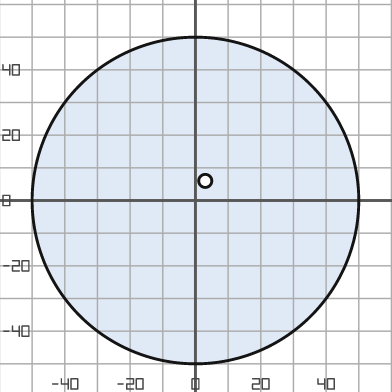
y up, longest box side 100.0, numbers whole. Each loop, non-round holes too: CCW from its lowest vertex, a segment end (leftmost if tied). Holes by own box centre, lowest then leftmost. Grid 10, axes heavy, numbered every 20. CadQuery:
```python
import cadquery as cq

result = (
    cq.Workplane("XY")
    .moveTo(0.0, 0.0)
    .circle(50.0)
    .moveTo(3.0, 6.0)
    .circle(2.0)
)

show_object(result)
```